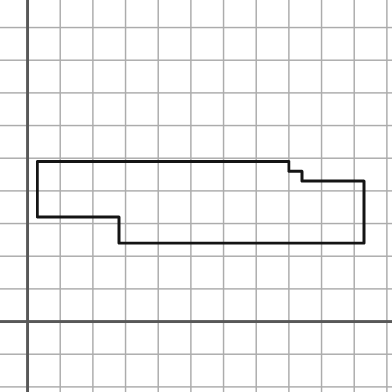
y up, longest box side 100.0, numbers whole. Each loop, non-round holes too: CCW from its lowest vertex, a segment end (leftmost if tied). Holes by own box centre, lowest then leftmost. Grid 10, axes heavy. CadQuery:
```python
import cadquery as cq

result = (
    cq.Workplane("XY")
    .moveTo(28.0, 24.0)
    .lineTo(103.0, 24.0)
    .lineTo(103.0, 43.0)
    .lineTo(84.0, 43.0)
    .lineTo(84.0, 46.0)
    .lineTo(80.0, 46.0)
    .lineTo(80.0, 49.0)
    .lineTo(3.0, 49.0)
    .lineTo(3.0, 32.0)
    .lineTo(28.0, 32.0)
    .close()
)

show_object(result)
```